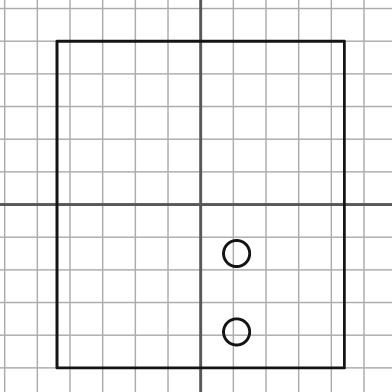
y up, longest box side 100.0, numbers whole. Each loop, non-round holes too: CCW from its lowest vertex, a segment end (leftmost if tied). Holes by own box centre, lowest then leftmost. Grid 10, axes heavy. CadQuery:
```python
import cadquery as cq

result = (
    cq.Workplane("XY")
    .moveTo(-44.0, -50.0)
    .lineTo(44.0, -50.0)
    .lineTo(44.0, 50.0)
    .lineTo(-44.0, 50.0)
    .close()
    .moveTo(11.0, -39.0)
    .circle(4.0)
    .moveTo(11.0, -15.0)
    .circle(4.0)
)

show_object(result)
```